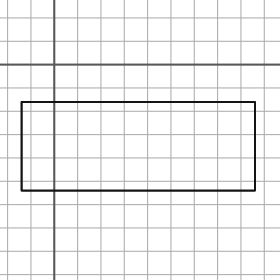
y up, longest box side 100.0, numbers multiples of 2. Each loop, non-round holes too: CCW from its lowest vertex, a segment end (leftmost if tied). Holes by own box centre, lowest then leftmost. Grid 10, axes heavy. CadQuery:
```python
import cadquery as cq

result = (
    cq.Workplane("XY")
    .moveTo(-14.0, -54.0)
    .lineTo(86.0, -54.0)
    .lineTo(86.0, -16.0)
    .lineTo(-14.0, -16.0)
    .close()
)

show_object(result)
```